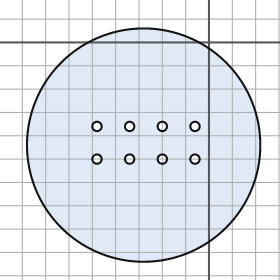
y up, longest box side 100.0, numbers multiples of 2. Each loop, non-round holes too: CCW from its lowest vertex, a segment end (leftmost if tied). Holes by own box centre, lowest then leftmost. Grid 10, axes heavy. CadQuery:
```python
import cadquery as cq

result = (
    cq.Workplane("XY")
    .moveTo(-28.0, -44.0)
    .circle(50.0)
    .moveTo(-48.0, -50.0)
    .circle(2.0)
    .moveTo(-34.0, -50.0)
    .circle(2.0)
    .moveTo(-20.0, -50.0)
    .circle(2.0)
    .moveTo(-6.0, -50.0)
    .circle(2.0)
    .moveTo(-48.0, -36.0)
    .circle(2.0)
    .moveTo(-34.0, -36.0)
    .circle(2.0)
    .moveTo(-20.0, -36.0)
    .circle(2.0)
    .moveTo(-6.0, -36.0)
    .circle(2.0)
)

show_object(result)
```